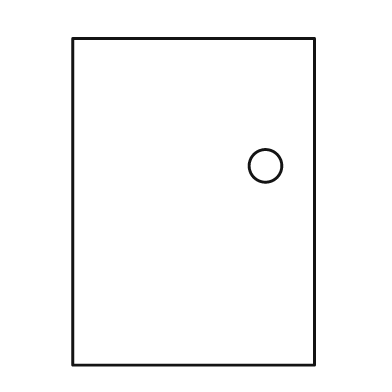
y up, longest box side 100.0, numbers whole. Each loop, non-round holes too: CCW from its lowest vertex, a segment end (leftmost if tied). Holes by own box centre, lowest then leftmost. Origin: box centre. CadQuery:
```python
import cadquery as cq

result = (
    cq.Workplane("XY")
    .moveTo(-37.0, -50.0)
    .lineTo(37.0, -50.0)
    .lineTo(37.0, 50.0)
    .lineTo(-37.0, 50.0)
    .close()
    .moveTo(22.0, 11.0)
    .circle(5.0)
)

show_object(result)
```